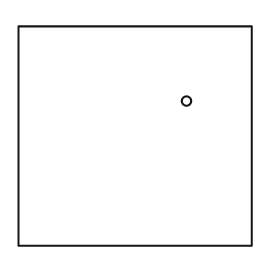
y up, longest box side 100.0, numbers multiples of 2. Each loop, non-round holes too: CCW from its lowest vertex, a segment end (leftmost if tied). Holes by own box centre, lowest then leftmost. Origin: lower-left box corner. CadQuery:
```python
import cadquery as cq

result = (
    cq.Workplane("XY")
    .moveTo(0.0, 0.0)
    .lineTo(100.0, 0.0)
    .lineTo(100.0, 94.0)
    .lineTo(0.0, 94.0)
    .close()
    .moveTo(72.0, 62.0)
    .circle(2.0)
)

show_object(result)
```